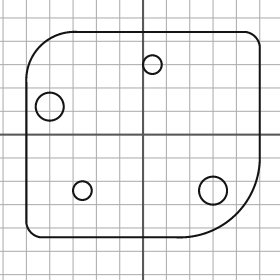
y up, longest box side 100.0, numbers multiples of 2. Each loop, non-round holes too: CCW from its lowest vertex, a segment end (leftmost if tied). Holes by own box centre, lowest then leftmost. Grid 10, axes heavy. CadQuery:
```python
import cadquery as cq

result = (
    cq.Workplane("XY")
    .moveTo(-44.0, -44.0)
    .lineTo(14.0, -44.0)
    .threePointArc((40.0, -34.0), (50.0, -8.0))
    .lineTo(50.0, 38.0)
    .threePointArc((48.0, 42.0), (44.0, 44.0))
    .lineTo(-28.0, 44.0)
    .threePointArc((-44.0, 38.0), (-50.0, 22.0))
    .lineTo(-50.0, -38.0)
    .threePointArc((-48.0, -42.0), (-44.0, -44.0))
    .close()
    .moveTo(-26.0, -24.0)
    .circle(4.0)
    .moveTo(30.0, -24.0)
    .circle(6.0)
    .moveTo(-40.0, 12.0)
    .circle(6.0)
    .moveTo(4.0, 30.0)
    .circle(4.0)
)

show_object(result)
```